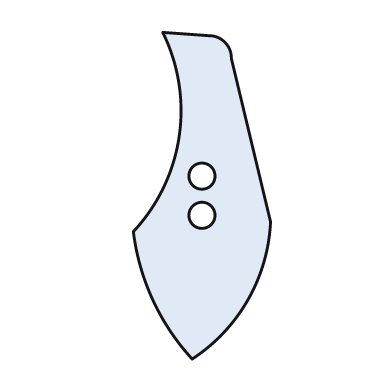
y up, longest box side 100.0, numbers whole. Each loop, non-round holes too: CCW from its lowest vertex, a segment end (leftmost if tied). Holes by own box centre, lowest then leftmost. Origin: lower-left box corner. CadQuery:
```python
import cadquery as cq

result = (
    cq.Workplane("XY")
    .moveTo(18.0, 0.0)
    .threePointArc((35.0, 18.0), (42.0, 42.0))
    .lineTo(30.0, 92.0)
    .threePointArc((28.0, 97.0), (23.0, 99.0))
    .lineTo(9.0, 100.0)
    .threePointArc((14.0, 68.0), (0.0, 39.0))
    .threePointArc((6.0, 18.0), (18.0, 0.0))
    .close()
    .moveTo(21.0, 44.0)
    .circle(4.0)
    .moveTo(21.0, 56.0)
    .circle(4.0)
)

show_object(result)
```